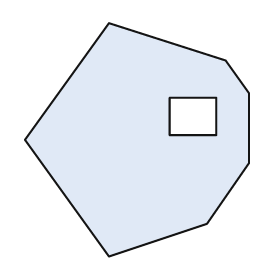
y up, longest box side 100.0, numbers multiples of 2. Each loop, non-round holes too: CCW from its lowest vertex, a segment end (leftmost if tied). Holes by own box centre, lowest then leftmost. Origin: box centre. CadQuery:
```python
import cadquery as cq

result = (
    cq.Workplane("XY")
    .moveTo(-12.0, -50.0)
    .lineTo(30.0, -36.0)
    .lineTo(48.0, -10.0)
    .lineTo(48.0, 20.0)
    .lineTo(38.0, 34.0)
    .lineTo(-12.0, 50.0)
    .lineTo(-48.0, 0.0)
    .close()
    .moveTo(14.0, 2.0)
    .lineTo(34.0, 2.0)
    .lineTo(34.0, 18.0)
    .lineTo(14.0, 18.0)
    .close()
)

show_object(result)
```